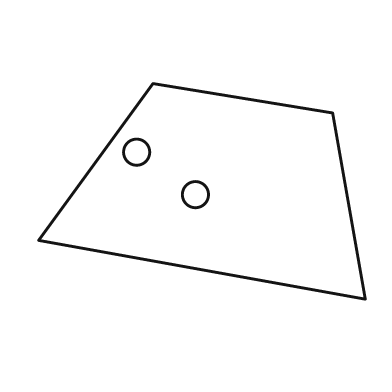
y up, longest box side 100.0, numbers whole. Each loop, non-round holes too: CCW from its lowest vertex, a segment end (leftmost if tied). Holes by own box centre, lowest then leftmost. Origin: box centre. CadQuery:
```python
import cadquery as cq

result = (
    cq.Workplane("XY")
    .moveTo(50.0, -33.0)
    .lineTo(40.0, 24.0)
    .lineTo(-15.0, 33.0)
    .lineTo(-50.0, -15.0)
    .close()
    .moveTo(-2.0, -1.0)
    .circle(4.0)
    .moveTo(-20.0, 12.0)
    .circle(4.0)
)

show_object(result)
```